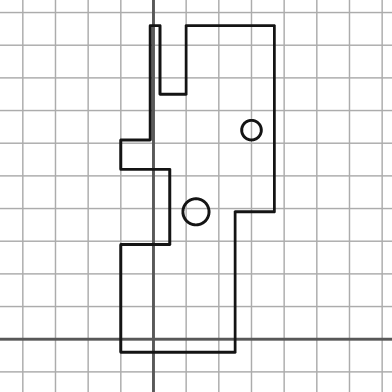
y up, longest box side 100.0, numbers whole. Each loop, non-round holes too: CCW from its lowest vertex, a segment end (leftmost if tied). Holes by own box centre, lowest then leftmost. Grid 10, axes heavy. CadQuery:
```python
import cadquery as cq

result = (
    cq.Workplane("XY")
    .moveTo(-10.0, -4.0)
    .lineTo(25.0, -4.0)
    .lineTo(25.0, 39.0)
    .lineTo(37.0, 39.0)
    .lineTo(37.0, 96.0)
    .lineTo(10.0, 96.0)
    .lineTo(10.0, 75.0)
    .lineTo(2.0, 75.0)
    .lineTo(2.0, 96.0)
    .lineTo(-1.0, 96.0)
    .lineTo(-1.0, 61.0)
    .lineTo(-10.0, 61.0)
    .lineTo(-10.0, 52.0)
    .lineTo(5.0, 52.0)
    .lineTo(5.0, 29.0)
    .lineTo(-10.0, 29.0)
    .close()
    .moveTo(13.0, 39.0)
    .circle(4.0)
    .moveTo(30.0, 64.0)
    .circle(3.0)
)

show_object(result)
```